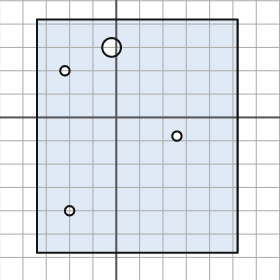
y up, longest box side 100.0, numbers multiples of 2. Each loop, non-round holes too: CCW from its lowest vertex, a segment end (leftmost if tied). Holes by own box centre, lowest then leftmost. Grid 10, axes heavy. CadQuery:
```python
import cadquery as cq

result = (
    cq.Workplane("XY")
    .moveTo(-34.0, -58.0)
    .lineTo(52.0, -58.0)
    .lineTo(52.0, 42.0)
    .lineTo(-34.0, 42.0)
    .close()
    .moveTo(-20.0, -40.0)
    .circle(2.0)
    .moveTo(26.0, -8.0)
    .circle(2.0)
    .moveTo(-22.0, 20.0)
    .circle(2.0)
    .moveTo(-2.0, 30.0)
    .circle(4.0)
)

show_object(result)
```